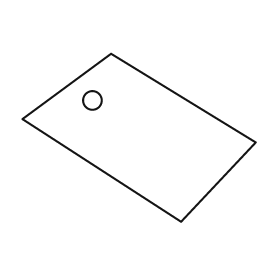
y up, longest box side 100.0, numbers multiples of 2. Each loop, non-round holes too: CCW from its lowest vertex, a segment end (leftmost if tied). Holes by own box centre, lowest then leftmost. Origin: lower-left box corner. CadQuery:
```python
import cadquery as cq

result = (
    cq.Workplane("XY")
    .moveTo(68.0, 0.0)
    .lineTo(100.0, 34.0)
    .lineTo(38.0, 72.0)
    .lineTo(0.0, 44.0)
    .close()
    .moveTo(30.0, 52.0)
    .circle(4.0)
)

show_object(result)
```